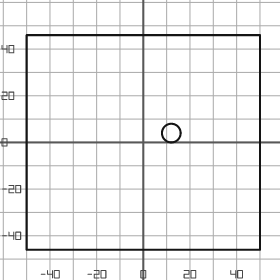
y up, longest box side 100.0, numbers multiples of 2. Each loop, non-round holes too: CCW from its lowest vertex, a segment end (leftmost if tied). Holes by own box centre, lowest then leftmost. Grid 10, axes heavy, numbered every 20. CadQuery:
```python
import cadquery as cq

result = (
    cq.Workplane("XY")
    .moveTo(-50.0, -46.0)
    .lineTo(50.0, -46.0)
    .lineTo(50.0, 46.0)
    .lineTo(-50.0, 46.0)
    .close()
    .moveTo(12.0, 4.0)
    .circle(4.0)
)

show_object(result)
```